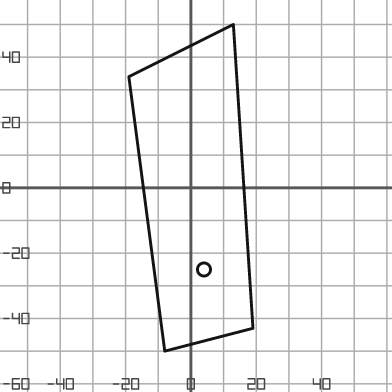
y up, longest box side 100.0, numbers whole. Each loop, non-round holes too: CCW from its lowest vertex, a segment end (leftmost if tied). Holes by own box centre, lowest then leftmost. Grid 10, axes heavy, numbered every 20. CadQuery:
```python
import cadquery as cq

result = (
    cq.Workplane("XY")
    .moveTo(-8.0, -50.0)
    .lineTo(19.0, -43.0)
    .lineTo(13.0, 50.0)
    .lineTo(-19.0, 34.0)
    .close()
    .moveTo(4.0, -25.0)
    .circle(2.0)
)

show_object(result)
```